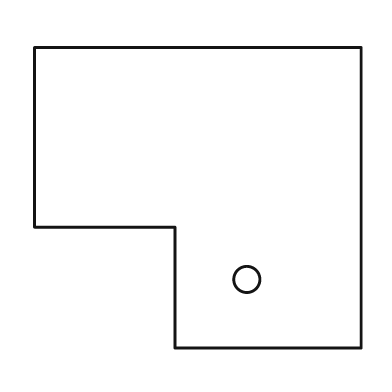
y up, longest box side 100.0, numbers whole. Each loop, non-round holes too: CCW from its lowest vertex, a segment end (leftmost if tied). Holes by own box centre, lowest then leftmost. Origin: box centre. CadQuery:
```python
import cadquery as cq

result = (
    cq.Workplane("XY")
    .moveTo(-7.0, -46.0)
    .lineTo(50.0, -46.0)
    .lineTo(50.0, 46.0)
    .lineTo(-50.0, 46.0)
    .lineTo(-50.0, -9.0)
    .lineTo(-7.0, -9.0)
    .close()
    .moveTo(15.0, -25.0)
    .circle(4.0)
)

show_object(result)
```